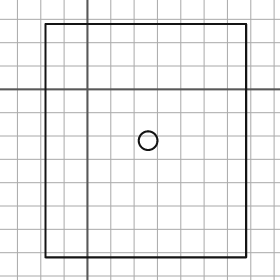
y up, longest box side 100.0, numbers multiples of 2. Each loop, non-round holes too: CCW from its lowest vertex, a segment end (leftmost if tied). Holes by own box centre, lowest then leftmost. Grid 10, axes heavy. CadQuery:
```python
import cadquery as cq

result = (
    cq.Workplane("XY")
    .moveTo(-18.0, -72.0)
    .lineTo(68.0, -72.0)
    .lineTo(68.0, 28.0)
    .lineTo(-18.0, 28.0)
    .close()
    .moveTo(26.0, -22.0)
    .circle(4.0)
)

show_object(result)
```